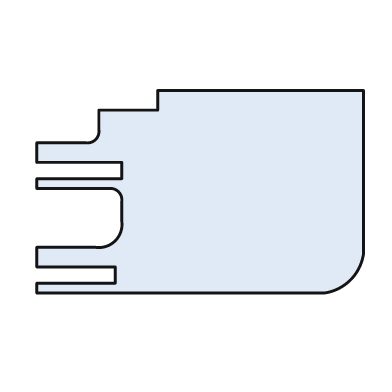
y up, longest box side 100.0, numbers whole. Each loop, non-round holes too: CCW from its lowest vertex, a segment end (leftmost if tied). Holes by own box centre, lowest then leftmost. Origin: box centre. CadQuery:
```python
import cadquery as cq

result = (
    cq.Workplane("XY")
    .moveTo(-50.0, -31.0)
    .lineTo(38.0, -31.0)
    .threePointArc((46.0, -27.0), (50.0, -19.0))
    .lineTo(50.0, 31.0)
    .lineTo(-13.0, 31.0)
    .lineTo(-13.0, 25.0)
    .lineTo(-31.0, 25.0)
    .lineTo(-31.0, 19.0)
    .threePointArc((-32.0, 16.0), (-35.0, 15.0))
    .lineTo(-50.0, 15.0)
    .lineTo(-50.0, 9.0)
    .lineTo(-24.0, 9.0)
    .lineTo(-24.0, 4.0)
    .lineTo(-50.0, 4.0)
    .lineTo(-50.0, 1.0)
    .lineTo(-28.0, 1.0)
    .threePointArc((-25.0, 0.0), (-24.0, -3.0))
    .lineTo(-24.0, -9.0)
    .threePointArc((-26.0, -15.0), (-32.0, -17.0))
    .lineTo(-50.0, -17.0)
    .lineTo(-50.0, -23.0)
    .lineTo(-26.0, -23.0)
    .lineTo(-26.0, -28.0)
    .lineTo(-50.0, -28.0)
    .close()
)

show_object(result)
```